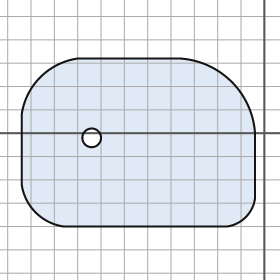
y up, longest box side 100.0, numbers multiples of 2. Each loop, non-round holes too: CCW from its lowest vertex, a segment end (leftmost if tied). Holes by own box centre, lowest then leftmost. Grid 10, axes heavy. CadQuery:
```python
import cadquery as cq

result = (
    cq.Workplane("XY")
    .moveTo(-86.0, -40.0)
    .lineTo(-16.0, -40.0)
    .threePointArc((-8.0, -36.0), (-4.0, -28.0))
    .lineTo(-4.0, 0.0)
    .threePointArc((-14.0, 22.0), (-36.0, 32.0))
    .lineTo(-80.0, 32.0)
    .threePointArc((-96.0, 24.0), (-104.0, 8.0))
    .lineTo(-104.0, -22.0)
    .threePointArc((-98.0, -34.0), (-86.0, -40.0))
    .close()
    .moveTo(-74.0, -2.0)
    .circle(4.0)
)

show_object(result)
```